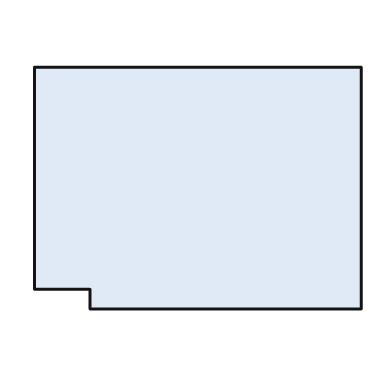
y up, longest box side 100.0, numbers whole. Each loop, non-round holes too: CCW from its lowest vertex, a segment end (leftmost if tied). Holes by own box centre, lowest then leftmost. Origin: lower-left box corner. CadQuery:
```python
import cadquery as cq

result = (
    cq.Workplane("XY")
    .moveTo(17.0, 0.0)
    .lineTo(100.0, 0.0)
    .lineTo(100.0, 74.0)
    .lineTo(0.0, 74.0)
    .lineTo(0.0, 6.0)
    .lineTo(17.0, 6.0)
    .close()
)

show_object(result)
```